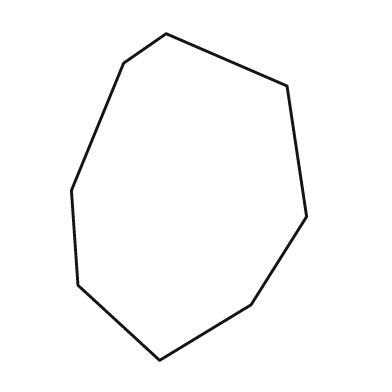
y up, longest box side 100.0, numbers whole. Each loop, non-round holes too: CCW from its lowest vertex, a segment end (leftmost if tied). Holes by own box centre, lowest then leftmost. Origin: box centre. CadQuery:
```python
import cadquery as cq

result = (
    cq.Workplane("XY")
    .moveTo(-9.0, -50.0)
    .lineTo(19.0, -33.0)
    .lineTo(36.0, -6.0)
    .lineTo(30.0, 34.0)
    .lineTo(-7.0, 50.0)
    .lineTo(-20.0, 41.0)
    .lineTo(-36.0, 2.0)
    .lineTo(-34.0, -27.0)
    .close()
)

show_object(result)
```